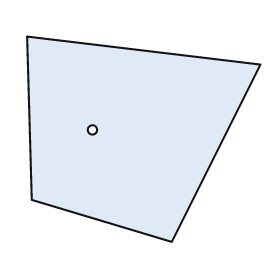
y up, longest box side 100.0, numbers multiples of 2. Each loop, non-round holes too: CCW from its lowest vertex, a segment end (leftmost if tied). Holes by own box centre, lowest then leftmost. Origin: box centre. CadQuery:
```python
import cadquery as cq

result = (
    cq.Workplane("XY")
    .moveTo(12.0, -44.0)
    .lineTo(50.0, 32.0)
    .lineTo(-50.0, 44.0)
    .lineTo(-48.0, -26.0)
    .close()
    .moveTo(-22.0, 4.0)
    .circle(2.0)
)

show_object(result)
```